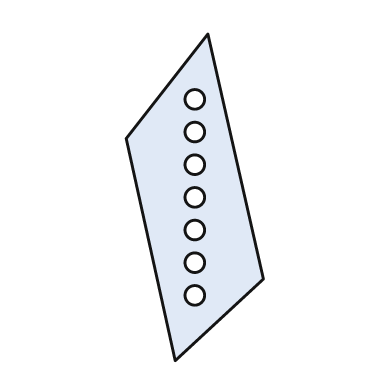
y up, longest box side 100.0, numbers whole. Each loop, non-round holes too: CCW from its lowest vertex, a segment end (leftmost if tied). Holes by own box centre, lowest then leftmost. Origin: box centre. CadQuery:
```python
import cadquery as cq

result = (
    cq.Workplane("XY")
    .moveTo(-6.0, -50.0)
    .lineTo(21.0, -25.0)
    .lineTo(4.0, 50.0)
    .lineTo(-21.0, 18.0)
    .close()
    .moveTo(0.0, -30.0)
    .circle(3.0)
    .moveTo(0.0, -20.0)
    .circle(3.0)
    .moveTo(0.0, -10.0)
    .circle(3.0)
    .moveTo(0.0, 0.0)
    .circle(3.0)
    .moveTo(0.0, 10.0)
    .circle(3.0)
    .moveTo(0.0, 20.0)
    .circle(3.0)
    .moveTo(0.0, 30.0)
    .circle(3.0)
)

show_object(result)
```